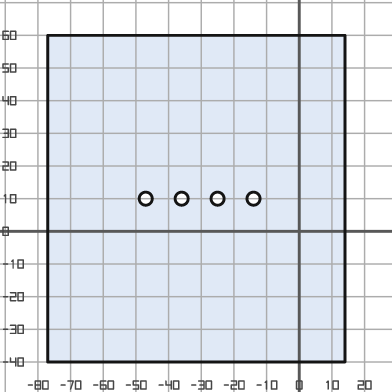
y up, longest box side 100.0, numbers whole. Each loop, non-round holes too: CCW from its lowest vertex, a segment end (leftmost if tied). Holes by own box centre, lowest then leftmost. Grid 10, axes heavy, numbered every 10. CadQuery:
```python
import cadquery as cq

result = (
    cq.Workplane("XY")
    .moveTo(-77.0, -40.0)
    .lineTo(14.0, -40.0)
    .lineTo(14.0, 60.0)
    .lineTo(-77.0, 60.0)
    .close()
    .moveTo(-47.0, 10.0)
    .circle(2.0)
    .moveTo(-36.0, 10.0)
    .circle(2.0)
    .moveTo(-25.0, 10.0)
    .circle(2.0)
    .moveTo(-14.0, 10.0)
    .circle(2.0)
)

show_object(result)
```